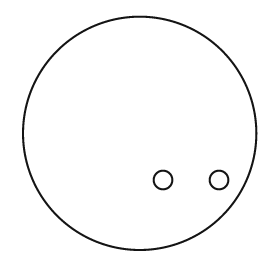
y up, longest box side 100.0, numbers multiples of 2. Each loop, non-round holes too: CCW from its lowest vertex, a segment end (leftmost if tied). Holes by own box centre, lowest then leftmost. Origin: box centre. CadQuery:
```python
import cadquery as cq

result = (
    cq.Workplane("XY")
    .moveTo(0.0, 0.0)
    .circle(50.0)
    .moveTo(10.0, -20.0)
    .circle(4.0)
    .moveTo(34.0, -20.0)
    .circle(4.0)
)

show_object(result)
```